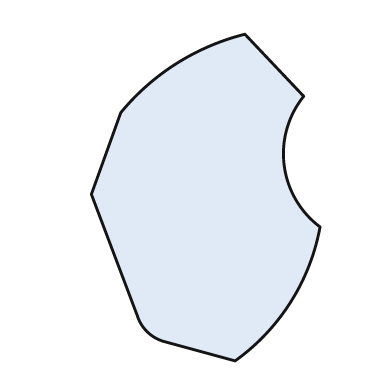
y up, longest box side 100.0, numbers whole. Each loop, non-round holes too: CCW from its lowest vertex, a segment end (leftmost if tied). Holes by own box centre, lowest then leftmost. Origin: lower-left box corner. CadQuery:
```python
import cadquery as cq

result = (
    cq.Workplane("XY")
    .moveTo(44.0, 0.0)
    .threePointArc((61.0, 18.0), (70.0, 41.0))
    .threePointArc((59.0, 60.0), (65.0, 81.0))
    .lineTo(47.0, 100.0)
    .threePointArc((26.0, 91.0), (9.0, 76.0))
    .lineTo(0.0, 51.0)
    .lineTo(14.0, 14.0)
    .threePointArc((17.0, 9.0), (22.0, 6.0))
    .close()
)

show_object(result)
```